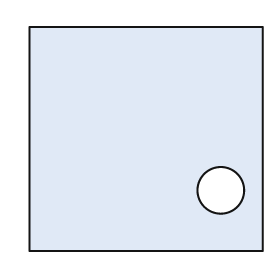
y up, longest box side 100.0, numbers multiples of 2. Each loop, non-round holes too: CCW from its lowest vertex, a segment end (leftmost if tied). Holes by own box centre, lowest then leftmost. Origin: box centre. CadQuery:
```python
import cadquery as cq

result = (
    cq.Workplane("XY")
    .moveTo(-50.0, -48.0)
    .lineTo(50.0, -48.0)
    .lineTo(50.0, 48.0)
    .lineTo(-50.0, 48.0)
    .close()
    .moveTo(32.0, -22.0)
    .circle(10.0)
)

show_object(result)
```